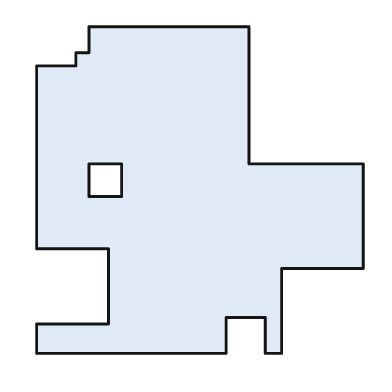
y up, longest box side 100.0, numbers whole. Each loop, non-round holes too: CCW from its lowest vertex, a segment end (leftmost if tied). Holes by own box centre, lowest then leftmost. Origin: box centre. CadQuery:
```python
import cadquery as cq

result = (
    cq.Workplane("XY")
    .moveTo(-50.0, -50.0)
    .lineTo(8.0, -50.0)
    .lineTo(8.0, -39.0)
    .lineTo(20.0, -39.0)
    .lineTo(20.0, -50.0)
    .lineTo(25.0, -50.0)
    .lineTo(25.0, -24.0)
    .lineTo(50.0, -24.0)
    .lineTo(50.0, 8.0)
    .lineTo(15.0, 8.0)
    .lineTo(15.0, 50.0)
    .lineTo(-34.0, 50.0)
    .lineTo(-34.0, 42.0)
    .lineTo(-38.0, 42.0)
    .lineTo(-38.0, 38.0)
    .lineTo(-50.0, 38.0)
    .lineTo(-50.0, -18.0)
    .lineTo(-28.0, -18.0)
    .lineTo(-28.0, -41.0)
    .lineTo(-50.0, -41.0)
    .close()
    .moveTo(-34.0, -2.0)
    .lineTo(-24.0, -2.0)
    .lineTo(-24.0, 8.0)
    .lineTo(-34.0, 8.0)
    .close()
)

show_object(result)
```